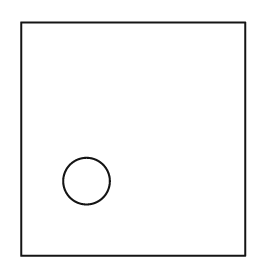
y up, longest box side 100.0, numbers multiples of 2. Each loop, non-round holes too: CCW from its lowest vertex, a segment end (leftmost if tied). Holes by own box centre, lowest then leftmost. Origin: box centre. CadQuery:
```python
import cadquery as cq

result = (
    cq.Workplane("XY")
    .moveTo(-48.0, -50.0)
    .lineTo(48.0, -50.0)
    .lineTo(48.0, 50.0)
    .lineTo(-48.0, 50.0)
    .close()
    .moveTo(-20.0, -18.0)
    .circle(10.0)
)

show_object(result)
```